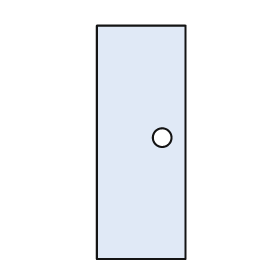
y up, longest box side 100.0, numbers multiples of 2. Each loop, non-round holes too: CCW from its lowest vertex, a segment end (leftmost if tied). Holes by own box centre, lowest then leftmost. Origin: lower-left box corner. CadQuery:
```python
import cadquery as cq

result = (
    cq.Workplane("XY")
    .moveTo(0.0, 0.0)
    .lineTo(38.0, 0.0)
    .lineTo(38.0, 100.0)
    .lineTo(0.0, 100.0)
    .close()
    .moveTo(28.0, 52.0)
    .circle(4.0)
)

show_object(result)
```